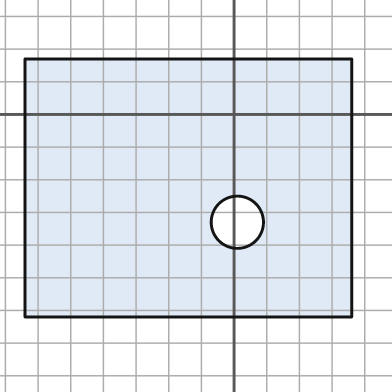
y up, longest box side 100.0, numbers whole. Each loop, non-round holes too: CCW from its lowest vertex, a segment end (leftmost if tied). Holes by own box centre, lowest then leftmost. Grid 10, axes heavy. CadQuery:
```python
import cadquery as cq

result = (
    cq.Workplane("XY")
    .moveTo(-64.0, -62.0)
    .lineTo(36.0, -62.0)
    .lineTo(36.0, 17.0)
    .lineTo(-64.0, 17.0)
    .close()
    .moveTo(1.0, -33.0)
    .circle(8.0)
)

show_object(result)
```